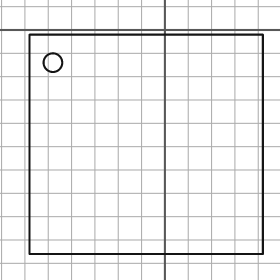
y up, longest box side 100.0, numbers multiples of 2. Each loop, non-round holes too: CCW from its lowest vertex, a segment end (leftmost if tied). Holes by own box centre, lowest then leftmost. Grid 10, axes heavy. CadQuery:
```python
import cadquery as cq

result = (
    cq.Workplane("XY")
    .moveTo(-58.0, -96.0)
    .lineTo(42.0, -96.0)
    .lineTo(42.0, -2.0)
    .lineTo(-58.0, -2.0)
    .close()
    .moveTo(-48.0, -14.0)
    .circle(4.0)
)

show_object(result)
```